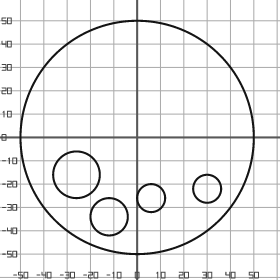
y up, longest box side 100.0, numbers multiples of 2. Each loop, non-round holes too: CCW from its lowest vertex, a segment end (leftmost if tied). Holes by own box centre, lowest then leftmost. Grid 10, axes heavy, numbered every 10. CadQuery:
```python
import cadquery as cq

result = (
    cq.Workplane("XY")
    .moveTo(0.0, 0.0)
    .circle(50.0)
    .moveTo(-12.0, -34.0)
    .circle(8.0)
    .moveTo(6.0, -26.0)
    .circle(6.0)
    .moveTo(30.0, -22.0)
    .circle(6.0)
    .moveTo(-26.0, -16.0)
    .circle(10.0)
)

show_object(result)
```